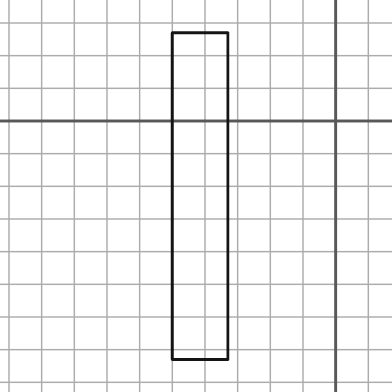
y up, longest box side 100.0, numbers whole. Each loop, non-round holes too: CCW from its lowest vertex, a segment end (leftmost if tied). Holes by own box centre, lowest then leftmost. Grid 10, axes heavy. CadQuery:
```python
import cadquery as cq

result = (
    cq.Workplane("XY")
    .moveTo(-50.0, -73.0)
    .lineTo(-33.0, -73.0)
    .lineTo(-33.0, 27.0)
    .lineTo(-50.0, 27.0)
    .close()
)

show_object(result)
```